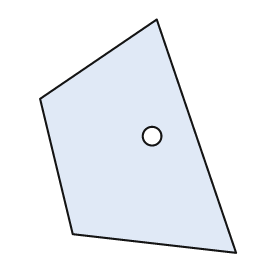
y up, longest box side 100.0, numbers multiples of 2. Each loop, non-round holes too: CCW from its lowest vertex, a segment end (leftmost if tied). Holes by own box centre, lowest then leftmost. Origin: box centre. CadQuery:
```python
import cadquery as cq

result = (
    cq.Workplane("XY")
    .moveTo(42.0, -50.0)
    .lineTo(8.0, 50.0)
    .lineTo(-42.0, 16.0)
    .lineTo(-28.0, -42.0)
    .close()
    .moveTo(6.0, 0.0)
    .circle(4.0)
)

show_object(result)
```